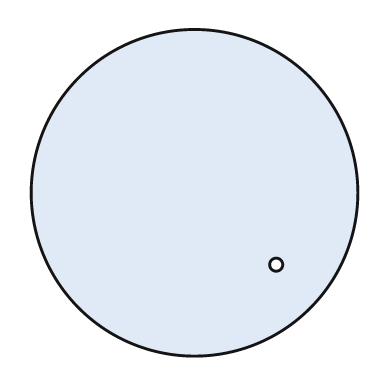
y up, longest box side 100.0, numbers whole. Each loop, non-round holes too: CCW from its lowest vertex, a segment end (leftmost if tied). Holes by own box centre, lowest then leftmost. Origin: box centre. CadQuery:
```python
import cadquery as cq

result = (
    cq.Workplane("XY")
    .moveTo(0.0, 0.0)
    .circle(50.0)
    .moveTo(25.0, -22.0)
    .circle(2.0)
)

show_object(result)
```